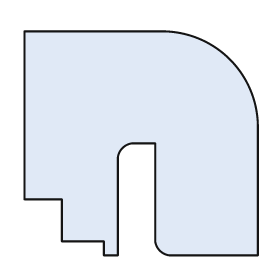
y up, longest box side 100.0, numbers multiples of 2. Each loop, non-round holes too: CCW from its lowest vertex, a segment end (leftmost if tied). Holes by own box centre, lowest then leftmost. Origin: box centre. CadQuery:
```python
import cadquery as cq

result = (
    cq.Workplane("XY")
    .moveTo(-16.0, -48.0)
    .lineTo(-10.0, -48.0)
    .lineTo(-10.0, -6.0)
    .threePointArc((-8.0, -2.0), (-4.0, 0.0))
    .lineTo(6.0, 0.0)
    .lineTo(6.0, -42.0)
    .threePointArc((8.0, -46.0), (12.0, -48.0))
    .lineTo(50.0, -48.0)
    .lineTo(50.0, 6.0)
    .threePointArc((38.0, 36.0), (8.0, 48.0))
    .lineTo(-50.0, 48.0)
    .lineTo(-50.0, -24.0)
    .lineTo(-34.0, -24.0)
    .lineTo(-34.0, -42.0)
    .lineTo(-16.0, -42.0)
    .close()
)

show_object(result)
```